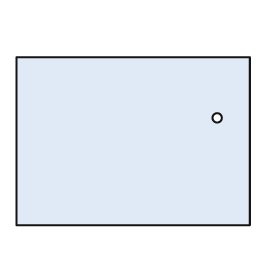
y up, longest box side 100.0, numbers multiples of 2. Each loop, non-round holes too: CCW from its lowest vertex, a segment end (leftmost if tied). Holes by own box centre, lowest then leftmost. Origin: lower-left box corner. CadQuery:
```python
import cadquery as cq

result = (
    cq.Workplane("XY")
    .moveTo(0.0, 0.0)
    .lineTo(100.0, 0.0)
    .lineTo(100.0, 72.0)
    .lineTo(0.0, 72.0)
    .close()
    .moveTo(86.0, 46.0)
    .circle(2.0)
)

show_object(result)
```